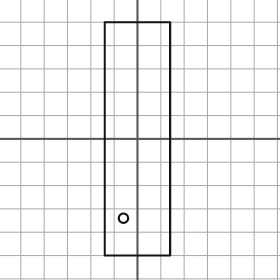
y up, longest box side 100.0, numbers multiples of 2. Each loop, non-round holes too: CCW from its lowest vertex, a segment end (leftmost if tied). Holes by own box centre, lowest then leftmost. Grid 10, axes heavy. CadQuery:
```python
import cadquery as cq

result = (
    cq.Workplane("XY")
    .moveTo(-14.0, -50.0)
    .lineTo(14.0, -50.0)
    .lineTo(14.0, 50.0)
    .lineTo(-14.0, 50.0)
    .close()
    .moveTo(-6.0, -34.0)
    .circle(2.0)
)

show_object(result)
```